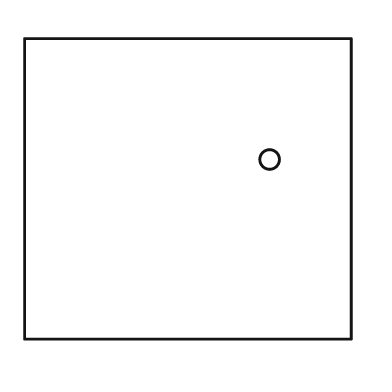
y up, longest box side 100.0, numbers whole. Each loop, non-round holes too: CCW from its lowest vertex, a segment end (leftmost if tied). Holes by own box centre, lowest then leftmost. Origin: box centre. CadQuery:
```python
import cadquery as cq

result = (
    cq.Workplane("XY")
    .moveTo(-50.0, -46.0)
    .lineTo(50.0, -46.0)
    .lineTo(50.0, 46.0)
    .lineTo(-50.0, 46.0)
    .close()
    .moveTo(25.0, 9.0)
    .circle(3.0)
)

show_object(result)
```